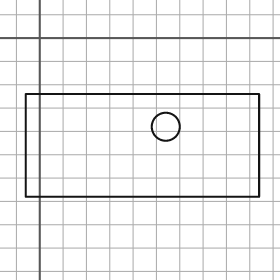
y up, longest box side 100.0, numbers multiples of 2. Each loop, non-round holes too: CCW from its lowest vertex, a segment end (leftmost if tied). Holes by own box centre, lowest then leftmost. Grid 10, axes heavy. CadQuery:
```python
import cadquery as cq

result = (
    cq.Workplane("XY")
    .moveTo(-6.0, -68.0)
    .lineTo(94.0, -68.0)
    .lineTo(94.0, -24.0)
    .lineTo(-6.0, -24.0)
    .close()
    .moveTo(54.0, -38.0)
    .circle(6.0)
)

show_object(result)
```